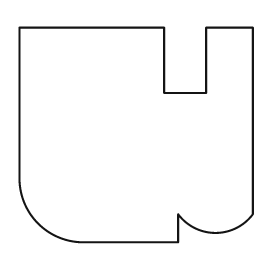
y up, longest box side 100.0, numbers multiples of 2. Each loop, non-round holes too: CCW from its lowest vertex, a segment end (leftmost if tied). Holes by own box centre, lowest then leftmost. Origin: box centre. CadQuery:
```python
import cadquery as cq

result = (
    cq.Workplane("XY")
    .moveTo(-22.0, -46.0)
    .lineTo(18.0, -46.0)
    .lineTo(18.0, -34.0)
    .threePointArc((34.0, -42.0), (50.0, -34.0))
    .lineTo(50.0, 46.0)
    .lineTo(30.0, 46.0)
    .lineTo(30.0, 18.0)
    .lineTo(12.0, 18.0)
    .lineTo(12.0, 46.0)
    .lineTo(-50.0, 46.0)
    .lineTo(-50.0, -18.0)
    .threePointArc((-42.0, -38.0), (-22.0, -46.0))
    .close()
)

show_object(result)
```